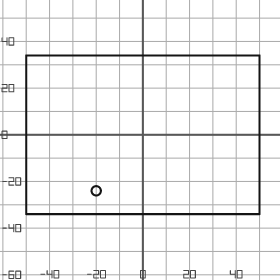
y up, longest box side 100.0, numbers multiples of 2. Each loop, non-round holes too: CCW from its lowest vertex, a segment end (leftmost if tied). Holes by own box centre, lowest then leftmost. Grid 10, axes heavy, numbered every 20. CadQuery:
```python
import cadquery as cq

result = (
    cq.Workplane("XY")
    .moveTo(-50.0, -34.0)
    .lineTo(50.0, -34.0)
    .lineTo(50.0, 34.0)
    .lineTo(-50.0, 34.0)
    .close()
    .moveTo(-20.0, -24.0)
    .circle(2.0)
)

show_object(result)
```